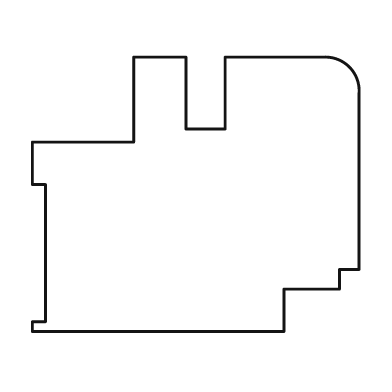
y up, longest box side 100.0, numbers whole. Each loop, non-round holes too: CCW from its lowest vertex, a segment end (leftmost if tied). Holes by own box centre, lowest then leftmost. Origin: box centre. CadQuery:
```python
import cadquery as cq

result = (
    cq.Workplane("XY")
    .moveTo(-50.0, -42.0)
    .lineTo(27.0, -42.0)
    .lineTo(27.0, -29.0)
    .lineTo(44.0, -29.0)
    .lineTo(44.0, -23.0)
    .lineTo(50.0, -23.0)
    .lineTo(50.0, 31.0)
    .threePointArc((47.0, 39.0), (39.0, 42.0))
    .lineTo(9.0, 42.0)
    .lineTo(9.0, 20.0)
    .lineTo(-3.0, 20.0)
    .lineTo(-3.0, 42.0)
    .lineTo(-19.0, 42.0)
    .lineTo(-19.0, 16.0)
    .lineTo(-50.0, 16.0)
    .lineTo(-50.0, 3.0)
    .lineTo(-46.0, 3.0)
    .lineTo(-46.0, -39.0)
    .lineTo(-50.0, -39.0)
    .close()
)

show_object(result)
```